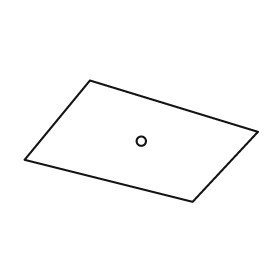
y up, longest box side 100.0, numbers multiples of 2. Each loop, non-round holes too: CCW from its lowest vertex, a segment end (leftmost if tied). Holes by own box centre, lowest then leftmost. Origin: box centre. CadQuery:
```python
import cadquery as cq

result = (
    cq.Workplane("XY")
    .moveTo(22.0, -26.0)
    .lineTo(50.0, 4.0)
    .lineTo(-22.0, 26.0)
    .lineTo(-50.0, -8.0)
    .close()
    .moveTo(0.0, 0.0)
    .circle(2.0)
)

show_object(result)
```